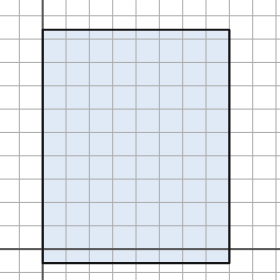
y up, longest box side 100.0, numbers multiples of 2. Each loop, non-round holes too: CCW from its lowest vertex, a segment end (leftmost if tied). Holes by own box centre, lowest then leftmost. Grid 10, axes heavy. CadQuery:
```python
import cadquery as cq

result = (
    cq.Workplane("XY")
    .moveTo(0.0, -6.0)
    .lineTo(80.0, -6.0)
    .lineTo(80.0, 94.0)
    .lineTo(0.0, 94.0)
    .close()
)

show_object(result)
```